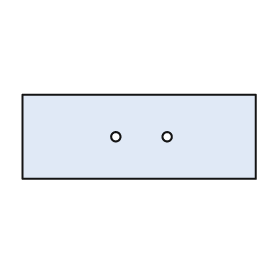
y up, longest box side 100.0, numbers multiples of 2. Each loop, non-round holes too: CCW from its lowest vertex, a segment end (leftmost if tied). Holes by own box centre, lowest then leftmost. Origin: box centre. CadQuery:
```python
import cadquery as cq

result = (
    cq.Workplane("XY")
    .moveTo(-50.0, -18.0)
    .lineTo(50.0, -18.0)
    .lineTo(50.0, 18.0)
    .lineTo(-50.0, 18.0)
    .close()
    .moveTo(-10.0, 0.0)
    .circle(2.0)
    .moveTo(12.0, 0.0)
    .circle(2.0)
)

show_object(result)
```